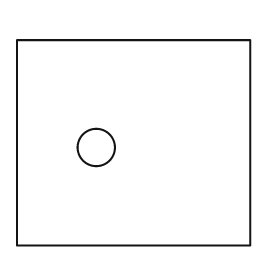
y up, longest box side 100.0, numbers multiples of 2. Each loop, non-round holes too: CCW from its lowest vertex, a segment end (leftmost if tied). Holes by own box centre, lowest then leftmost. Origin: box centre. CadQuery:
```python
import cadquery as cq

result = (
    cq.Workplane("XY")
    .moveTo(-50.0, -44.0)
    .lineTo(50.0, -44.0)
    .lineTo(50.0, 44.0)
    .lineTo(-50.0, 44.0)
    .close()
    .moveTo(-16.0, -2.0)
    .circle(8.0)
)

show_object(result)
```